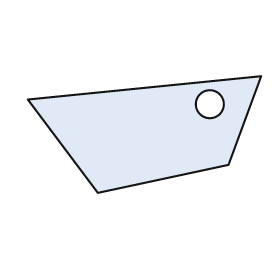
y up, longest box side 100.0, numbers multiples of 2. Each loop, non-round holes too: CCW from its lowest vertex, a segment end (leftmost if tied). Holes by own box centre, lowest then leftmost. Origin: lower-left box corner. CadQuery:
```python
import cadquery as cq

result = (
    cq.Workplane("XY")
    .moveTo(30.0, 0.0)
    .lineTo(86.0, 12.0)
    .lineTo(100.0, 50.0)
    .lineTo(0.0, 40.0)
    .close()
    .moveTo(78.0, 38.0)
    .circle(6.0)
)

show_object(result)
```